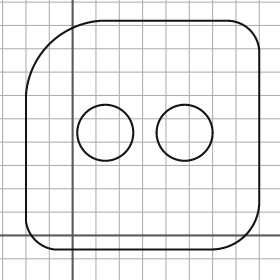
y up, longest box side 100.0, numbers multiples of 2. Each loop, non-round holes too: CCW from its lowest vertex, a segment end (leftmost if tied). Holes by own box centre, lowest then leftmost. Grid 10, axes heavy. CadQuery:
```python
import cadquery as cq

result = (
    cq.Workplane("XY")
    .moveTo(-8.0, -6.0)
    .lineTo(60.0, -6.0)
    .threePointArc((74.0, 0.0), (80.0, 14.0))
    .lineTo(80.0, 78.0)
    .threePointArc((76.0, 88.0), (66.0, 92.0))
    .lineTo(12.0, 92.0)
    .threePointArc((-10.0, 82.0), (-20.0, 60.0))
    .lineTo(-20.0, 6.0)
    .threePointArc((-16.0, -2.0), (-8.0, -6.0))
    .close()
    .moveTo(14.0, 44.0)
    .circle(12.0)
    .moveTo(48.0, 44.0)
    .circle(12.0)
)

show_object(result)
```